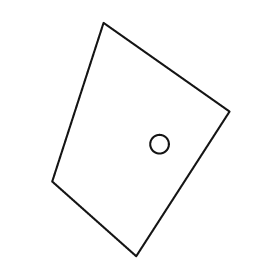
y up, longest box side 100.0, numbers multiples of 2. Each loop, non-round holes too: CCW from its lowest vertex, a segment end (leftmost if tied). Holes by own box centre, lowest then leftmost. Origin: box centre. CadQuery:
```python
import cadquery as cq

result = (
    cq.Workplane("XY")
    .moveTo(-2.0, -50.0)
    .lineTo(38.0, 12.0)
    .lineTo(-16.0, 50.0)
    .lineTo(-38.0, -18.0)
    .close()
    .moveTo(8.0, -2.0)
    .circle(4.0)
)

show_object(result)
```